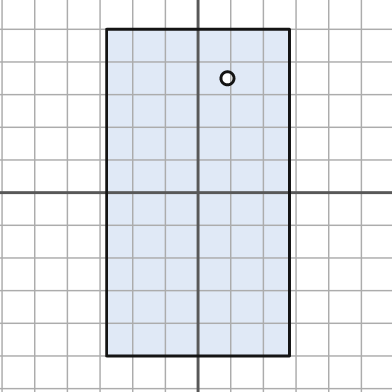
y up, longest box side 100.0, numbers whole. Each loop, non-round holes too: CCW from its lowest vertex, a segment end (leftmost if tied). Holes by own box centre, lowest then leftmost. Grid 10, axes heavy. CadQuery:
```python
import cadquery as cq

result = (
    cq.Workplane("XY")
    .moveTo(-28.0, -50.0)
    .lineTo(28.0, -50.0)
    .lineTo(28.0, 50.0)
    .lineTo(-28.0, 50.0)
    .close()
    .moveTo(9.0, 35.0)
    .circle(2.0)
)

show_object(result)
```